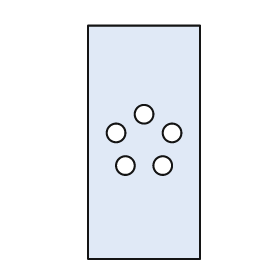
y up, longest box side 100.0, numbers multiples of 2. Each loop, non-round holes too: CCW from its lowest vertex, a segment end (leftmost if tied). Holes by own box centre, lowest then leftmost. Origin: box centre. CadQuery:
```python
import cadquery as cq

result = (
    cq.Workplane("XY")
    .moveTo(-24.0, -50.0)
    .lineTo(24.0, -50.0)
    .lineTo(24.0, 50.0)
    .lineTo(-24.0, 50.0)
    .close()
    .moveTo(-8.0, -10.0)
    .circle(4.0)
    .moveTo(8.0, -10.0)
    .circle(4.0)
    .moveTo(-12.0, 4.0)
    .circle(4.0)
    .moveTo(12.0, 4.0)
    .circle(4.0)
    .moveTo(0.0, 12.0)
    .circle(4.0)
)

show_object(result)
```